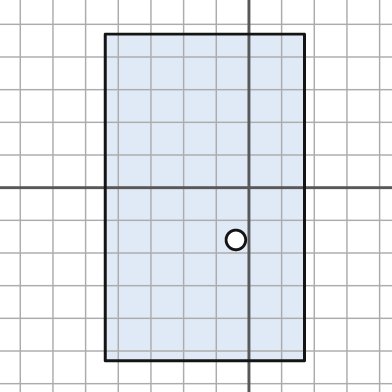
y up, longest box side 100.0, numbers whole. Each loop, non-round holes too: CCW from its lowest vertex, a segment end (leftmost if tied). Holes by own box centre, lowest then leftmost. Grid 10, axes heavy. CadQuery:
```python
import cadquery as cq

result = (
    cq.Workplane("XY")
    .moveTo(-44.0, -53.0)
    .lineTo(17.0, -53.0)
    .lineTo(17.0, 47.0)
    .lineTo(-44.0, 47.0)
    .close()
    .moveTo(-4.0, -16.0)
    .circle(3.0)
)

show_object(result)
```